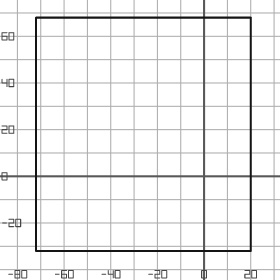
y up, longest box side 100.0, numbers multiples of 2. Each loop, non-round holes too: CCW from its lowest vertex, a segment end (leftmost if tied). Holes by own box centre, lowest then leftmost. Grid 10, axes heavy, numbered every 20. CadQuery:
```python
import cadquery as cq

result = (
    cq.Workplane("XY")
    .moveTo(-72.0, -32.0)
    .lineTo(20.0, -32.0)
    .lineTo(20.0, 68.0)
    .lineTo(-72.0, 68.0)
    .close()
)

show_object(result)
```